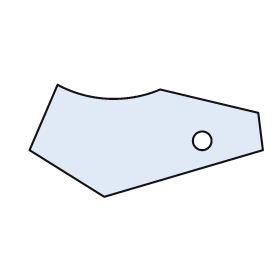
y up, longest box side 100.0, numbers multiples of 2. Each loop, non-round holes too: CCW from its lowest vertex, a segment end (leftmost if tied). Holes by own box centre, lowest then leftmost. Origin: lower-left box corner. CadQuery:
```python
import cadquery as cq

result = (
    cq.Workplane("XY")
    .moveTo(32.0, 0.0)
    .lineTo(100.0, 20.0)
    .lineTo(98.0, 36.0)
    .lineTo(56.0, 46.0)
    .threePointArc((34.0, 42.0), (12.0, 48.0))
    .lineTo(0.0, 20.0)
    .close()
    .moveTo(74.0, 24.0)
    .circle(4.0)
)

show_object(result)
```